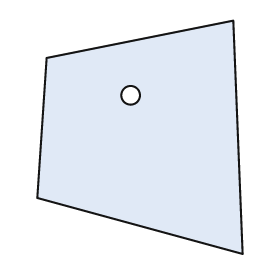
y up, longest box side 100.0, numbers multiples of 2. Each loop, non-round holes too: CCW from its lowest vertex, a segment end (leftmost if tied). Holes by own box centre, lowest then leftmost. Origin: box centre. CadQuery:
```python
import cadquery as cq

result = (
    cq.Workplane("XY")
    .moveTo(44.0, -50.0)
    .lineTo(40.0, 50.0)
    .lineTo(-40.0, 34.0)
    .lineTo(-44.0, -26.0)
    .close()
    .moveTo(-4.0, 18.0)
    .circle(4.0)
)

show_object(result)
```